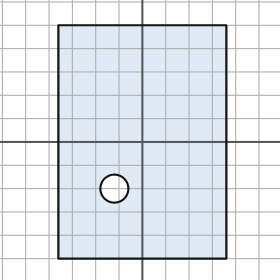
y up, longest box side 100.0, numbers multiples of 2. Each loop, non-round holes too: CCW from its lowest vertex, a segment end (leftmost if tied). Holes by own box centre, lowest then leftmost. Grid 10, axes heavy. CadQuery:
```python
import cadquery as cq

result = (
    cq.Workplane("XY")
    .moveTo(-36.0, -50.0)
    .lineTo(36.0, -50.0)
    .lineTo(36.0, 50.0)
    .lineTo(-36.0, 50.0)
    .close()
    .moveTo(-12.0, -20.0)
    .circle(6.0)
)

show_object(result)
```